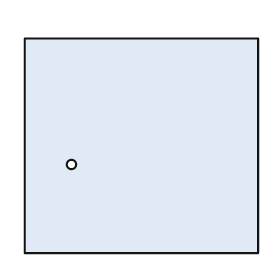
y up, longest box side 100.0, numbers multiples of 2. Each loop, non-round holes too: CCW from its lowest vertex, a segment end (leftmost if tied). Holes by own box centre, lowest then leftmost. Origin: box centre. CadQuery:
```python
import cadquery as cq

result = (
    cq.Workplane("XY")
    .moveTo(-50.0, -46.0)
    .lineTo(50.0, -46.0)
    .lineTo(50.0, 46.0)
    .lineTo(-50.0, 46.0)
    .close()
    .moveTo(-30.0, -8.0)
    .circle(2.0)
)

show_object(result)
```